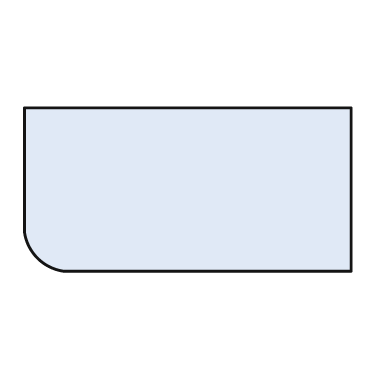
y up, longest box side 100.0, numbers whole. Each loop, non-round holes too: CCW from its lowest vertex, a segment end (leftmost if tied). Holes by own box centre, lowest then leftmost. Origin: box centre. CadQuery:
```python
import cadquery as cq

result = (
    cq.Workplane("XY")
    .moveTo(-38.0, -25.0)
    .lineTo(50.0, -25.0)
    .lineTo(50.0, 25.0)
    .lineTo(-50.0, 25.0)
    .lineTo(-50.0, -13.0)
    .threePointArc((-46.0, -21.0), (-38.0, -25.0))
    .close()
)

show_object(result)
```